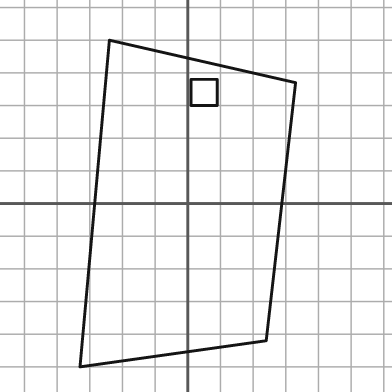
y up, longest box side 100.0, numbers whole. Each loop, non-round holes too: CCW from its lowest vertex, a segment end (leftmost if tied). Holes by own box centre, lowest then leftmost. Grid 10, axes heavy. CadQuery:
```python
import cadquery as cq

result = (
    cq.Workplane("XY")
    .moveTo(-33.0, -50.0)
    .lineTo(24.0, -42.0)
    .lineTo(33.0, 37.0)
    .lineTo(-24.0, 50.0)
    .close()
    .moveTo(1.0, 30.0)
    .lineTo(9.0, 30.0)
    .lineTo(9.0, 38.0)
    .lineTo(1.0, 38.0)
    .close()
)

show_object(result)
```